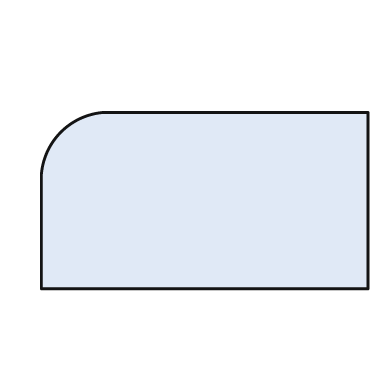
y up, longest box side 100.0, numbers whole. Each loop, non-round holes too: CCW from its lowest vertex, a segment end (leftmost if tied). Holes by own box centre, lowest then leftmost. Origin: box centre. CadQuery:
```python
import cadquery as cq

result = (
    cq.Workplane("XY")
    .moveTo(-50.0, -27.0)
    .lineTo(50.0, -27.0)
    .lineTo(50.0, 27.0)
    .lineTo(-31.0, 27.0)
    .threePointArc((-44.0, 21.0), (-50.0, 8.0))
    .close()
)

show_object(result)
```